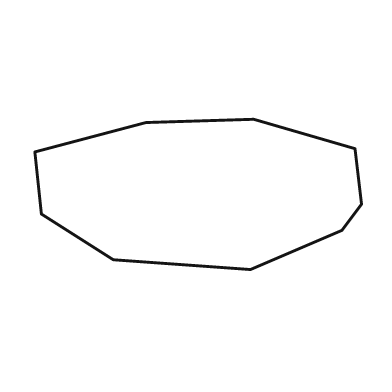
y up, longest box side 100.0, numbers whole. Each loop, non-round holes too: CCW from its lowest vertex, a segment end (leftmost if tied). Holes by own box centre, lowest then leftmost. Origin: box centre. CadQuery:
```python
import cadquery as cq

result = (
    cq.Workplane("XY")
    .moveTo(16.0, -23.0)
    .lineTo(44.0, -11.0)
    .lineTo(50.0, -3.0)
    .lineTo(48.0, 14.0)
    .lineTo(17.0, 23.0)
    .lineTo(-16.0, 22.0)
    .lineTo(-50.0, 13.0)
    .lineTo(-48.0, -6.0)
    .lineTo(-26.0, -20.0)
    .close()
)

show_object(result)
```